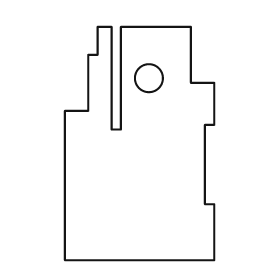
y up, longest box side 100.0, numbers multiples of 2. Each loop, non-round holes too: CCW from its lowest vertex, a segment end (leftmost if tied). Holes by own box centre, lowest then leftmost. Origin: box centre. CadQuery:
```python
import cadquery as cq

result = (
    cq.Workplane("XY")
    .moveTo(-32.0, -50.0)
    .lineTo(32.0, -50.0)
    .lineTo(32.0, -26.0)
    .lineTo(28.0, -26.0)
    .lineTo(28.0, 8.0)
    .lineTo(32.0, 8.0)
    .lineTo(32.0, 26.0)
    .lineTo(22.0, 26.0)
    .lineTo(22.0, 50.0)
    .lineTo(-8.0, 50.0)
    .lineTo(-8.0, 6.0)
    .lineTo(-12.0, 6.0)
    .lineTo(-12.0, 50.0)
    .lineTo(-18.0, 50.0)
    .lineTo(-18.0, 38.0)
    .lineTo(-22.0, 38.0)
    .lineTo(-22.0, 14.0)
    .lineTo(-32.0, 14.0)
    .close()
    .moveTo(4.0, 28.0)
    .circle(6.0)
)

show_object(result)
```